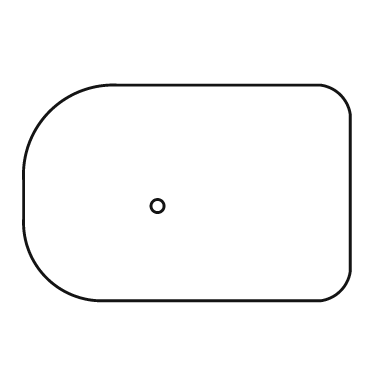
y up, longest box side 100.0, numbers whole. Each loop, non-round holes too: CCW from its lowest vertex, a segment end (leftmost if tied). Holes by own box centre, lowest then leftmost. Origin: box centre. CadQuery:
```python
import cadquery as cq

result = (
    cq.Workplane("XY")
    .moveTo(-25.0, -33.0)
    .lineTo(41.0, -33.0)
    .threePointArc((47.0, -30.0), (50.0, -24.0))
    .lineTo(50.0, 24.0)
    .threePointArc((47.0, 30.0), (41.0, 33.0))
    .lineTo(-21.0, 33.0)
    .threePointArc((-42.0, 25.0), (-50.0, 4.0))
    .lineTo(-50.0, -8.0)
    .threePointArc((-43.0, -26.0), (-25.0, -33.0))
    .close()
    .moveTo(-9.0, -4.0)
    .circle(2.0)
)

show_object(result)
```